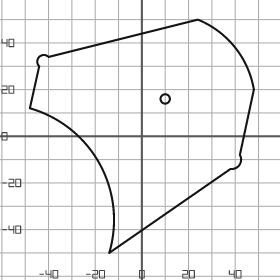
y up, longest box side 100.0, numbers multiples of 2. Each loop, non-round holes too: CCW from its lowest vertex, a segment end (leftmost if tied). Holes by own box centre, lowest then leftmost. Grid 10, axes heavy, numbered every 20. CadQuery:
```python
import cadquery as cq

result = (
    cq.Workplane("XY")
    .moveTo(-14.0, -50.0)
    .lineTo(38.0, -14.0)
    .threePointArc((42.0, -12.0), (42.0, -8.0))
    .lineTo(48.0, 20.0)
    .threePointArc((40.0, 38.0), (24.0, 50.0))
    .lineTo(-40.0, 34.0)
    .threePointArc((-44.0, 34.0), (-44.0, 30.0))
    .lineTo(-48.0, 12.0)
    .threePointArc((-18.0, -12.0), (-14.0, -50.0))
    .close()
    .moveTo(10.0, 16.0)
    .circle(2.0)
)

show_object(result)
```